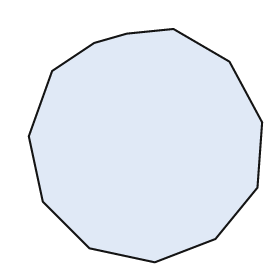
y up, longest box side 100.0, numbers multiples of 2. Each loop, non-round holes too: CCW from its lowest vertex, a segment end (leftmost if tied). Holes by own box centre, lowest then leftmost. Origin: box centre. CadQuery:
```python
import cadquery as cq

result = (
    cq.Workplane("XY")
    .moveTo(4.0, -50.0)
    .lineTo(30.0, -40.0)
    .lineTo(48.0, -18.0)
    .lineTo(50.0, 10.0)
    .lineTo(36.0, 36.0)
    .lineTo(12.0, 50.0)
    .lineTo(-8.0, 48.0)
    .lineTo(-22.0, 44.0)
    .lineTo(-40.0, 32.0)
    .lineTo(-50.0, 4.0)
    .lineTo(-44.0, -24.0)
    .lineTo(-24.0, -44.0)
    .close()
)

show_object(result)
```